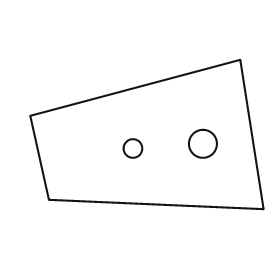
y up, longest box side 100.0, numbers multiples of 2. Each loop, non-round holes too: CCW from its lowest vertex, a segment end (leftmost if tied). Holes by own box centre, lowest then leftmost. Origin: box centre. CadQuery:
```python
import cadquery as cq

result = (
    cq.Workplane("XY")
    .moveTo(50.0, -32.0)
    .lineTo(40.0, 32.0)
    .lineTo(-50.0, 8.0)
    .lineTo(-42.0, -28.0)
    .close()
    .moveTo(-6.0, -6.0)
    .circle(4.0)
    .moveTo(24.0, -4.0)
    .circle(6.0)
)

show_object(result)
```